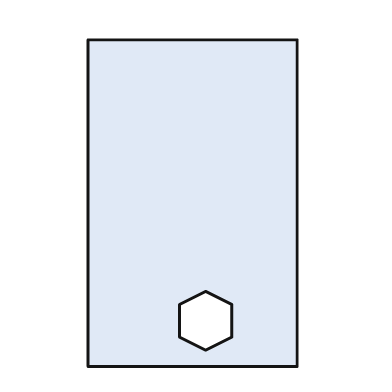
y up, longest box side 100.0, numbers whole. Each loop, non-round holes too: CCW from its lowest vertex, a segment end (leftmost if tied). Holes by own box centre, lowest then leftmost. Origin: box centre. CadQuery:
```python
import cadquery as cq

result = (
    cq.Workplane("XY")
    .moveTo(-32.0, -50.0)
    .lineTo(32.0, -50.0)
    .lineTo(32.0, 50.0)
    .lineTo(-32.0, 50.0)
    .close()
    .moveTo(4.0, -45.0)
    .lineTo(12.0, -41.0)
    .lineTo(12.0, -31.0)
    .lineTo(4.0, -27.0)
    .lineTo(-4.0, -31.0)
    .lineTo(-4.0, -41.0)
    .close()
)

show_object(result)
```